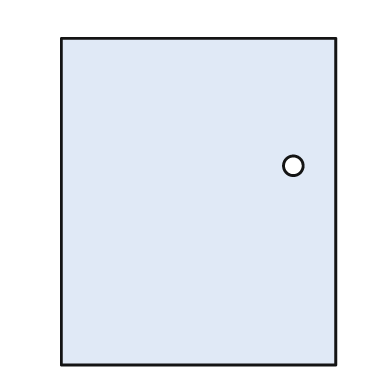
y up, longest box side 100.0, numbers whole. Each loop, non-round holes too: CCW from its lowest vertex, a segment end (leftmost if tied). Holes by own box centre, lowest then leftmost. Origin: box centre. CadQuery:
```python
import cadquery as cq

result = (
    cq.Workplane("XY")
    .moveTo(-42.0, -50.0)
    .lineTo(42.0, -50.0)
    .lineTo(42.0, 50.0)
    .lineTo(-42.0, 50.0)
    .close()
    .moveTo(29.0, 11.0)
    .circle(3.0)
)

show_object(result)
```